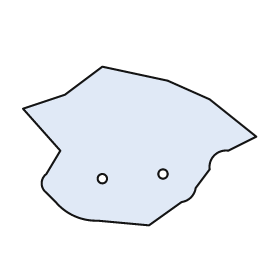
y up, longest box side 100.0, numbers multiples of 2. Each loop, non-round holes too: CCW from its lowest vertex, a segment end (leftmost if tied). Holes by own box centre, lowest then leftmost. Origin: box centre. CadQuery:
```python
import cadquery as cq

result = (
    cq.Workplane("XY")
    .moveTo(4.0, -34.0)
    .lineTo(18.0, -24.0)
    .threePointArc((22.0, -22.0), (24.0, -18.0))
    .lineTo(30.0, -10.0)
    .threePointArc((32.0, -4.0), (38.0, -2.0))
    .lineTo(50.0, 4.0)
    .lineTo(30.0, 20.0)
    .lineTo(12.0, 28.0)
    .lineTo(-16.0, 34.0)
    .lineTo(-32.0, 22.0)
    .lineTo(-50.0, 16.0)
    .lineTo(-34.0, -2.0)
    .lineTo(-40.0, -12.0)
    .threePointArc((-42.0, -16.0), (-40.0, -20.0))
    .lineTo(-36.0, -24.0)
    .threePointArc((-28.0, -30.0), (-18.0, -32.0))
    .close()
    .moveTo(-16.0, -14.0)
    .circle(2.0)
    .moveTo(10.0, -12.0)
    .circle(2.0)
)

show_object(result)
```